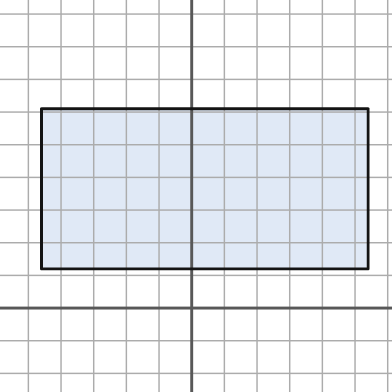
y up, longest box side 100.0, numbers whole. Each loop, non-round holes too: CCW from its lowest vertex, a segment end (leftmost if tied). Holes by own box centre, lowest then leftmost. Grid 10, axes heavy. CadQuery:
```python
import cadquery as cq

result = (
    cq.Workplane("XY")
    .moveTo(-46.0, 12.0)
    .lineTo(54.0, 12.0)
    .lineTo(54.0, 61.0)
    .lineTo(-46.0, 61.0)
    .close()
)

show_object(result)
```